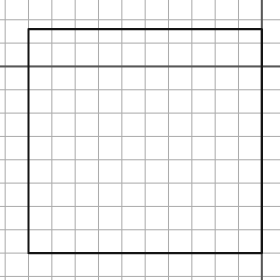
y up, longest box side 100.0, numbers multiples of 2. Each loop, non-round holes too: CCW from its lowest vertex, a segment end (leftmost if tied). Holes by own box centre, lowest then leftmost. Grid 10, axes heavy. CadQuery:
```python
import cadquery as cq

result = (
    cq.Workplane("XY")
    .moveTo(-100.0, -80.0)
    .lineTo(0.0, -80.0)
    .lineTo(0.0, 16.0)
    .lineTo(-100.0, 16.0)
    .close()
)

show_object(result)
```